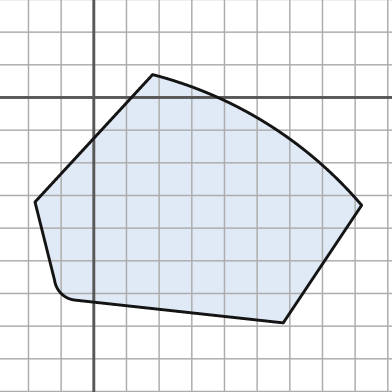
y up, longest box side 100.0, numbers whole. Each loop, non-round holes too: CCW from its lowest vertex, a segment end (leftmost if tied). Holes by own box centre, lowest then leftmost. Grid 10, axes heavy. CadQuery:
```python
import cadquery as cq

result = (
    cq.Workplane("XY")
    .moveTo(58.0, -69.0)
    .lineTo(82.0, -33.0)
    .threePointArc((53.0, -8.0), (18.0, 7.0))
    .lineTo(-18.0, -32.0)
    .lineTo(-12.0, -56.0)
    .threePointArc((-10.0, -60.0), (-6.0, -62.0))
    .close()
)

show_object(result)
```